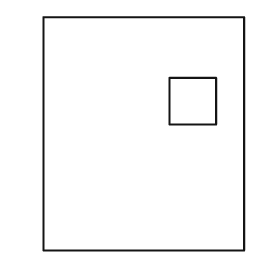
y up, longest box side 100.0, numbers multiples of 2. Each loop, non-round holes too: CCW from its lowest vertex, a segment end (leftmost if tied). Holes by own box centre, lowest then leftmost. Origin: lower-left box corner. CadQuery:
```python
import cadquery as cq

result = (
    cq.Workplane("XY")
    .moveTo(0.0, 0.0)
    .lineTo(86.0, 0.0)
    .lineTo(86.0, 100.0)
    .lineTo(0.0, 100.0)
    .close()
    .moveTo(54.0, 54.0)
    .lineTo(74.0, 54.0)
    .lineTo(74.0, 74.0)
    .lineTo(54.0, 74.0)
    .close()
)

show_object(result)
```